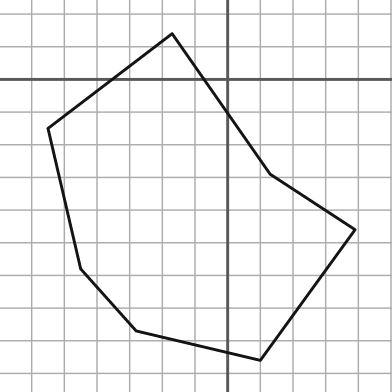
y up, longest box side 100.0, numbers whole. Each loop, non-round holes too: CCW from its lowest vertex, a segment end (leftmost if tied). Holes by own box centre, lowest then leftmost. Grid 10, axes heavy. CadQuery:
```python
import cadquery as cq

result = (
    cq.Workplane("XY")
    .moveTo(10.0, -86.0)
    .lineTo(39.0, -46.0)
    .lineTo(13.0, -29.0)
    .lineTo(-17.0, 14.0)
    .lineTo(-55.0, -15.0)
    .lineTo(-45.0, -58.0)
    .lineTo(-28.0, -77.0)
    .close()
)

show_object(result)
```